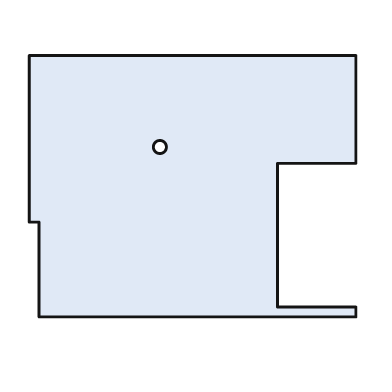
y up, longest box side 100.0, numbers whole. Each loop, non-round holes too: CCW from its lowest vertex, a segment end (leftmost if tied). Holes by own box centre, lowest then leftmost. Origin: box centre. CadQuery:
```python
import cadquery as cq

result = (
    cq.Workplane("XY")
    .moveTo(-47.0, -40.0)
    .lineTo(50.0, -40.0)
    .lineTo(50.0, -37.0)
    .lineTo(26.0, -37.0)
    .lineTo(26.0, 7.0)
    .lineTo(50.0, 7.0)
    .lineTo(50.0, 40.0)
    .lineTo(-50.0, 40.0)
    .lineTo(-50.0, -11.0)
    .lineTo(-47.0, -11.0)
    .close()
    .moveTo(-10.0, 12.0)
    .circle(2.0)
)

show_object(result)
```